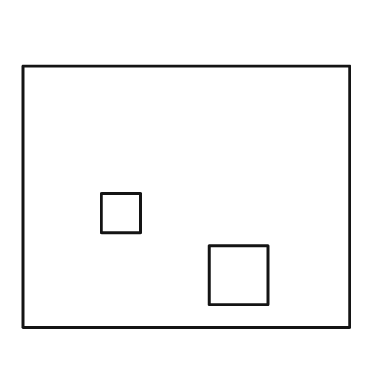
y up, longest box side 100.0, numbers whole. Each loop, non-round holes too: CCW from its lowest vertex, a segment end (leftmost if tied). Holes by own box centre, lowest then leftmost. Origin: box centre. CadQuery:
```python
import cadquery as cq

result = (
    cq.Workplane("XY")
    .moveTo(-50.0, -40.0)
    .lineTo(50.0, -40.0)
    .lineTo(50.0, 40.0)
    .lineTo(-50.0, 40.0)
    .close()
    .moveTo(7.0, -33.0)
    .lineTo(25.0, -33.0)
    .lineTo(25.0, -15.0)
    .lineTo(7.0, -15.0)
    .close()
    .moveTo(-26.0, -11.0)
    .lineTo(-14.0, -11.0)
    .lineTo(-14.0, 1.0)
    .lineTo(-26.0, 1.0)
    .close()
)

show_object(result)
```